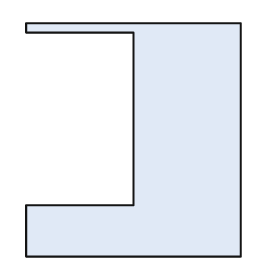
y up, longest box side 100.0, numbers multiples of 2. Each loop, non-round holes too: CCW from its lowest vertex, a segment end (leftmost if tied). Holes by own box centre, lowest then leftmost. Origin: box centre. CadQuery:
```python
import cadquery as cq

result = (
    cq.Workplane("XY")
    .moveTo(-46.0, -50.0)
    .lineTo(46.0, -50.0)
    .lineTo(46.0, 50.0)
    .lineTo(-46.0, 50.0)
    .lineTo(-46.0, 46.0)
    .lineTo(0.0, 46.0)
    .lineTo(0.0, -28.0)
    .lineTo(-46.0, -28.0)
    .close()
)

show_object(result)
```